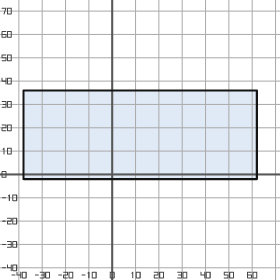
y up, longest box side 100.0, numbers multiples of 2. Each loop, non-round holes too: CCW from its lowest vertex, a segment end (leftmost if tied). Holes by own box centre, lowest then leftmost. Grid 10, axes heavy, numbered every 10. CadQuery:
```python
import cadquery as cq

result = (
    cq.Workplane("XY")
    .moveTo(-38.0, -2.0)
    .lineTo(62.0, -2.0)
    .lineTo(62.0, 36.0)
    .lineTo(-38.0, 36.0)
    .close()
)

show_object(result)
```